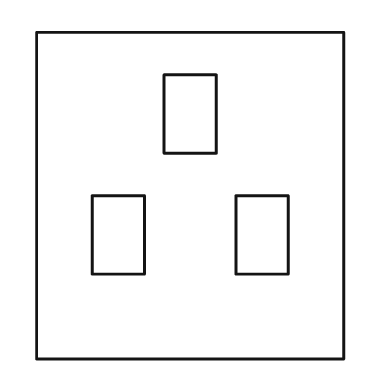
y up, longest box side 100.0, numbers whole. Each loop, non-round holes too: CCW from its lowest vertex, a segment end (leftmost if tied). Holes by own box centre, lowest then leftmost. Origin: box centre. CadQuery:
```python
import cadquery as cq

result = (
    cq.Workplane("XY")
    .moveTo(-47.0, -50.0)
    .lineTo(47.0, -50.0)
    .lineTo(47.0, 50.0)
    .lineTo(-47.0, 50.0)
    .close()
    .moveTo(-30.0, -24.0)
    .lineTo(-14.0, -24.0)
    .lineTo(-14.0, 0.0)
    .lineTo(-30.0, 0.0)
    .close()
    .moveTo(14.0, -24.0)
    .lineTo(30.0, -24.0)
    .lineTo(30.0, 0.0)
    .lineTo(14.0, 0.0)
    .close()
    .moveTo(-8.0, 13.0)
    .lineTo(8.0, 13.0)
    .lineTo(8.0, 37.0)
    .lineTo(-8.0, 37.0)
    .close()
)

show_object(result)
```